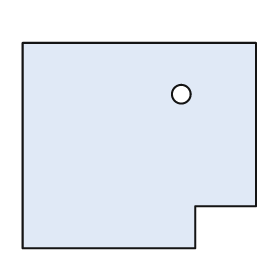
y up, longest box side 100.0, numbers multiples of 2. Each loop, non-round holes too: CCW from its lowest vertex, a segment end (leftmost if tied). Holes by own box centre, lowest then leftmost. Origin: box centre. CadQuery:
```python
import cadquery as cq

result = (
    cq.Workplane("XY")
    .moveTo(-50.0, -44.0)
    .lineTo(24.0, -44.0)
    .lineTo(24.0, -26.0)
    .lineTo(50.0, -26.0)
    .lineTo(50.0, 44.0)
    .lineTo(-50.0, 44.0)
    .close()
    .moveTo(18.0, 22.0)
    .circle(4.0)
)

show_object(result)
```